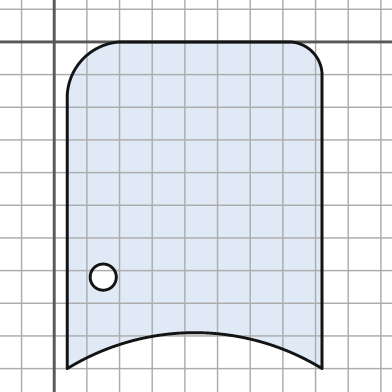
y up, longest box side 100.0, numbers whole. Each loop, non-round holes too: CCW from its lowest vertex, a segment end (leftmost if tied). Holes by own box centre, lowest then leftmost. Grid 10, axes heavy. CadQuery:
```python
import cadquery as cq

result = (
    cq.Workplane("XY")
    .moveTo(4.0, -100.0)
    .threePointArc((43.0, -89.0), (82.0, -100.0))
    .lineTo(82.0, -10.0)
    .threePointArc((79.0, -3.0), (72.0, 0.0))
    .lineTo(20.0, 0.0)
    .threePointArc((9.0, -5.0), (4.0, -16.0))
    .close()
    .moveTo(15.0, -72.0)
    .circle(4.0)
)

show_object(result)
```